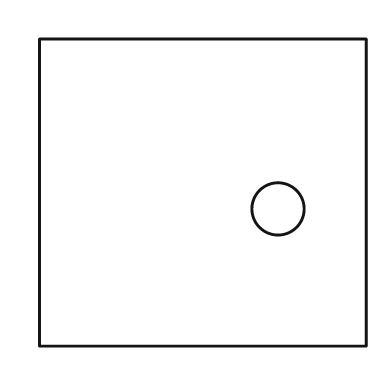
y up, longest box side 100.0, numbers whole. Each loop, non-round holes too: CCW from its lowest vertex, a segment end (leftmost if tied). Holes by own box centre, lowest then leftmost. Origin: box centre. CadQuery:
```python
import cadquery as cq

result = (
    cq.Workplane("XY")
    .moveTo(-50.0, -47.0)
    .lineTo(50.0, -47.0)
    .lineTo(50.0, 47.0)
    .lineTo(-50.0, 47.0)
    .close()
    .moveTo(23.0, -5.0)
    .circle(8.0)
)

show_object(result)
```